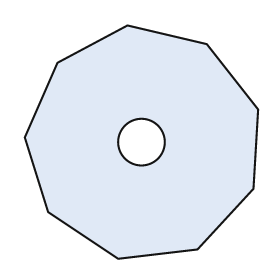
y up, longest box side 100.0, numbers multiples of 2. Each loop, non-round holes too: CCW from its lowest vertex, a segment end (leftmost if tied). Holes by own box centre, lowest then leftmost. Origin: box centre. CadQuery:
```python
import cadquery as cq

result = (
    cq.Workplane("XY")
    .moveTo(-10.0, -50.0)
    .lineTo(24.0, -46.0)
    .lineTo(48.0, -20.0)
    .lineTo(50.0, 14.0)
    .lineTo(28.0, 42.0)
    .lineTo(-6.0, 50.0)
    .lineTo(-36.0, 34.0)
    .lineTo(-50.0, 2.0)
    .lineTo(-40.0, -30.0)
    .close()
    .moveTo(0.0, 0.0)
    .circle(10.0)
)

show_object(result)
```